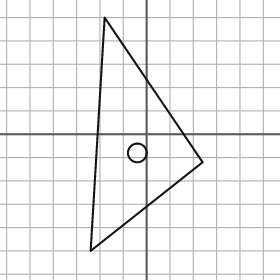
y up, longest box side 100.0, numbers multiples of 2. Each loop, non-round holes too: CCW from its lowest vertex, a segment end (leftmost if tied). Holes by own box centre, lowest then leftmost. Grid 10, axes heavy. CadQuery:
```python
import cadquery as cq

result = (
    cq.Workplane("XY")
    .moveTo(-24.0, -50.0)
    .lineTo(24.0, -12.0)
    .lineTo(-18.0, 50.0)
    .close()
    .moveTo(-4.0, -8.0)
    .circle(4.0)
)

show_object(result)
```